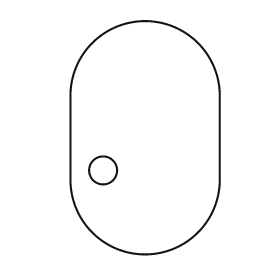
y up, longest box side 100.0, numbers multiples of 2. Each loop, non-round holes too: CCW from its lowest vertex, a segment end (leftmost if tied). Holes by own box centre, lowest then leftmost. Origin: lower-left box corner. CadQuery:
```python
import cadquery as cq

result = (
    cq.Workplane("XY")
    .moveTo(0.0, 32.0)
    .threePointArc((32.0, 0.0), (64.0, 32.0))
    .lineTo(64.0, 68.0)
    .threePointArc((32.0, 100.0), (0.0, 68.0))
    .close()
    .moveTo(14.0, 36.0)
    .circle(6.0)
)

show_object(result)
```